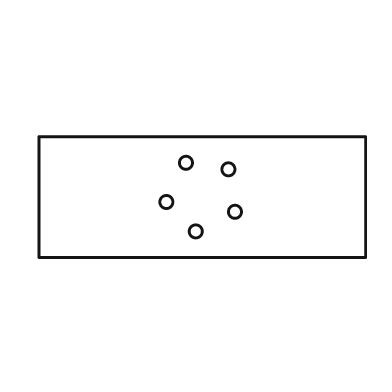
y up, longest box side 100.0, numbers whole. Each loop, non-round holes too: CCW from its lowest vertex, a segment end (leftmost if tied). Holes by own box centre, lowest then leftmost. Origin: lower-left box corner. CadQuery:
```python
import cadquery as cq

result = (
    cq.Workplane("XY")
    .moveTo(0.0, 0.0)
    .lineTo(100.0, 0.0)
    .lineTo(100.0, 37.0)
    .lineTo(0.0, 37.0)
    .close()
    .moveTo(48.0, 8.0)
    .circle(2.0)
    .moveTo(60.0, 14.0)
    .circle(2.0)
    .moveTo(39.0, 17.0)
    .circle(2.0)
    .moveTo(58.0, 27.0)
    .circle(2.0)
    .moveTo(45.0, 29.0)
    .circle(2.0)
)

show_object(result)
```